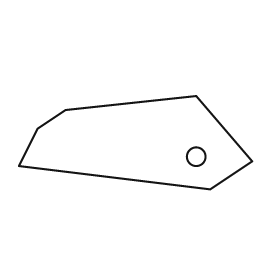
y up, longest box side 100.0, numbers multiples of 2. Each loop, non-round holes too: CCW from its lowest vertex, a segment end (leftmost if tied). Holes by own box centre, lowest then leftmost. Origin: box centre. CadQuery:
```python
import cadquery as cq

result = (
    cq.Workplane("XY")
    .moveTo(32.0, -20.0)
    .lineTo(50.0, -8.0)
    .lineTo(26.0, 20.0)
    .lineTo(-30.0, 14.0)
    .lineTo(-42.0, 6.0)
    .lineTo(-50.0, -10.0)
    .close()
    .moveTo(26.0, -6.0)
    .circle(4.0)
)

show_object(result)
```